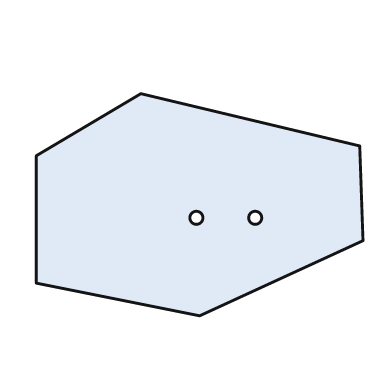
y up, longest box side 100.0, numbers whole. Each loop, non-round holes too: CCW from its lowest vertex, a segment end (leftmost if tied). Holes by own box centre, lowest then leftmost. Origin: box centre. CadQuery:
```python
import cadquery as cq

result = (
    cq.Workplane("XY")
    .moveTo(0.0, -34.0)
    .lineTo(50.0, -11.0)
    .lineTo(49.0, 18.0)
    .lineTo(-18.0, 34.0)
    .lineTo(-50.0, 15.0)
    .lineTo(-50.0, -24.0)
    .close()
    .moveTo(-1.0, -4.0)
    .circle(2.0)
    .moveTo(17.0, -4.0)
    .circle(2.0)
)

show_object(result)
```